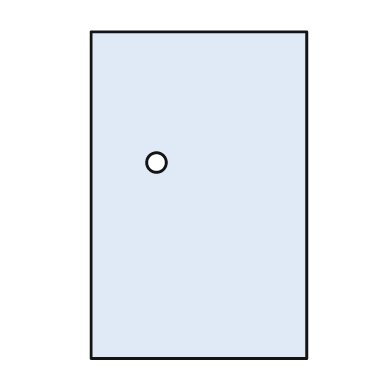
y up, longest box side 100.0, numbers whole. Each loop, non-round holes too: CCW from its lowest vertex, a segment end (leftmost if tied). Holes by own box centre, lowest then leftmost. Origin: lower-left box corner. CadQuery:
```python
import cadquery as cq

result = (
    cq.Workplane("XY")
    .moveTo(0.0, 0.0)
    .lineTo(66.0, 0.0)
    .lineTo(66.0, 100.0)
    .lineTo(0.0, 100.0)
    .close()
    .moveTo(20.0, 60.0)
    .circle(3.0)
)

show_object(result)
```